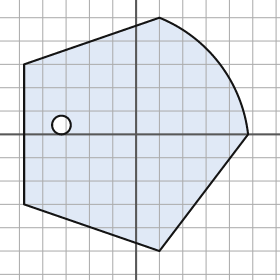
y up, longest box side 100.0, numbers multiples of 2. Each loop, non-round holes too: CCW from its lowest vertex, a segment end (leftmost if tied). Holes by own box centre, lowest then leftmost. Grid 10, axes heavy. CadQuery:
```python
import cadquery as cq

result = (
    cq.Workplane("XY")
    .moveTo(10.0, -50.0)
    .lineTo(48.0, 0.0)
    .threePointArc((36.0, 30.0), (10.0, 50.0))
    .lineTo(-48.0, 30.0)
    .lineTo(-48.0, -30.0)
    .close()
    .moveTo(-32.0, 4.0)
    .circle(4.0)
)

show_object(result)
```